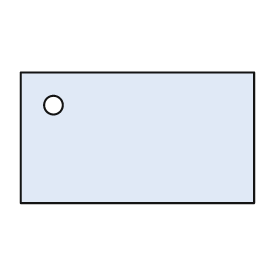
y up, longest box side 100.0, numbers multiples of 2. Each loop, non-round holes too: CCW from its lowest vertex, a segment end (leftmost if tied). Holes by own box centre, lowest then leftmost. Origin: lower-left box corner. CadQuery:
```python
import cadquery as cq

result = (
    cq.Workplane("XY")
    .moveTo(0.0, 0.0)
    .lineTo(100.0, 0.0)
    .lineTo(100.0, 56.0)
    .lineTo(0.0, 56.0)
    .close()
    .moveTo(14.0, 42.0)
    .circle(4.0)
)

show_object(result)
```